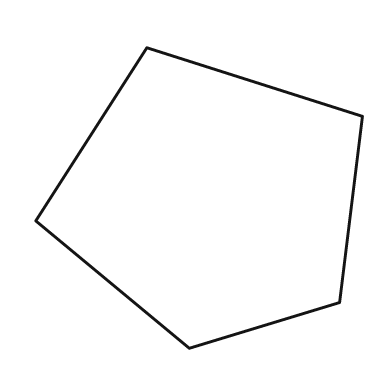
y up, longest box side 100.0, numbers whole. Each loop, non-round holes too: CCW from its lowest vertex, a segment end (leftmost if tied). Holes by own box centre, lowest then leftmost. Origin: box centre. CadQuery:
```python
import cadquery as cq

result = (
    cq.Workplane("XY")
    .moveTo(-3.0, -46.0)
    .lineTo(43.0, -32.0)
    .lineTo(50.0, 25.0)
    .lineTo(-16.0, 46.0)
    .lineTo(-50.0, -7.0)
    .close()
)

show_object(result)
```